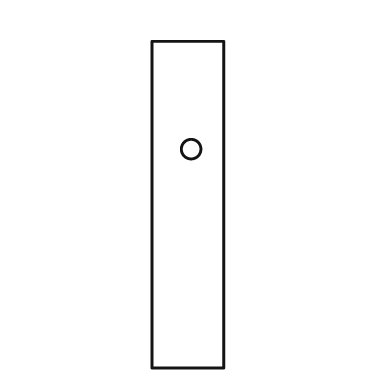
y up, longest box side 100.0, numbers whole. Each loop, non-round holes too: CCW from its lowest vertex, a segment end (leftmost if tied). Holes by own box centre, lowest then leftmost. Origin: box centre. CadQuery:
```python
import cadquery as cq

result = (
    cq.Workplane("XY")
    .moveTo(-11.0, -50.0)
    .lineTo(11.0, -50.0)
    .lineTo(11.0, 50.0)
    .lineTo(-11.0, 50.0)
    .close()
    .moveTo(1.0, 17.0)
    .circle(3.0)
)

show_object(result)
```